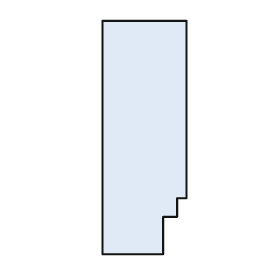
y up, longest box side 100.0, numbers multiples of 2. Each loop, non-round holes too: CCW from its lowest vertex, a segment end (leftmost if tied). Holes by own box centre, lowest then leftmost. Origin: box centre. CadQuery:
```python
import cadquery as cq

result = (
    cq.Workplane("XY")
    .moveTo(-18.0, -50.0)
    .lineTo(8.0, -50.0)
    .lineTo(8.0, -34.0)
    .lineTo(14.0, -34.0)
    .lineTo(14.0, -26.0)
    .lineTo(18.0, -26.0)
    .lineTo(18.0, 50.0)
    .lineTo(-18.0, 50.0)
    .close()
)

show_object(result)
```